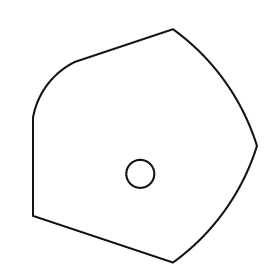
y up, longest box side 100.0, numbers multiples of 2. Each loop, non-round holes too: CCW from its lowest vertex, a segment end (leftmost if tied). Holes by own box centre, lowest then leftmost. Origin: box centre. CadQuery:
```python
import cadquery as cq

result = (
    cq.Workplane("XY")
    .moveTo(12.0, -50.0)
    .threePointArc((34.0, -28.0), (48.0, 0.0))
    .threePointArc((34.0, 28.0), (12.0, 50.0))
    .lineTo(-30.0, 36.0)
    .threePointArc((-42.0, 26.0), (-48.0, 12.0))
    .lineTo(-48.0, -30.0)
    .close()
    .moveTo(-2.0, -12.0)
    .circle(6.0)
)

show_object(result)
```